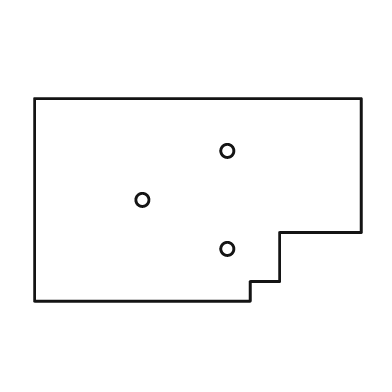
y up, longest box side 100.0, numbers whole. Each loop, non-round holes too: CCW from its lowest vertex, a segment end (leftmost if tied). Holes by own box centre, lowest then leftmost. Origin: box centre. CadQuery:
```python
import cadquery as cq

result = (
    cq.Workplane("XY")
    .moveTo(-50.0, -31.0)
    .lineTo(16.0, -31.0)
    .lineTo(16.0, -25.0)
    .lineTo(25.0, -25.0)
    .lineTo(25.0, -10.0)
    .lineTo(50.0, -10.0)
    .lineTo(50.0, 31.0)
    .lineTo(-50.0, 31.0)
    .close()
    .moveTo(9.0, -15.0)
    .circle(2.0)
    .moveTo(-17.0, 0.0)
    .circle(2.0)
    .moveTo(9.0, 15.0)
    .circle(2.0)
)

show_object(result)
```